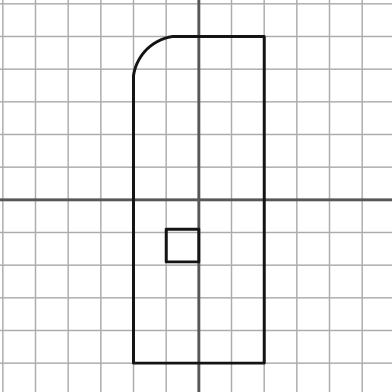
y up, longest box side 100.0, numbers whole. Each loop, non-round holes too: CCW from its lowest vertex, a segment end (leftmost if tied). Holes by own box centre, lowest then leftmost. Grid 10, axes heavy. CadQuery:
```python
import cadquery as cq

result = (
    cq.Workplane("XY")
    .moveTo(-20.0, -50.0)
    .lineTo(20.0, -50.0)
    .lineTo(20.0, 50.0)
    .lineTo(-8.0, 50.0)
    .threePointArc((-16.0, 46.0), (-20.0, 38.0))
    .close()
    .moveTo(-10.0, -19.0)
    .lineTo(0.0, -19.0)
    .lineTo(0.0, -9.0)
    .lineTo(-10.0, -9.0)
    .close()
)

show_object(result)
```